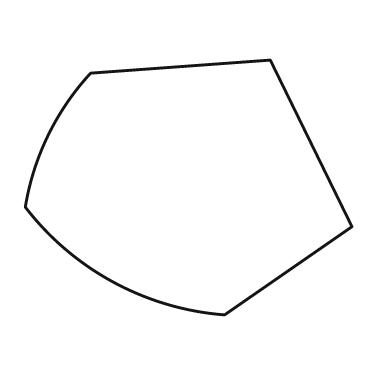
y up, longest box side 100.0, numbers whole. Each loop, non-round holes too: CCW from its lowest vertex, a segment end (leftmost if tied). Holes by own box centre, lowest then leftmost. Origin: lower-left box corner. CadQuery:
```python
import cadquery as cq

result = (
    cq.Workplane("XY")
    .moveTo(61.0, 0.0)
    .lineTo(100.0, 27.0)
    .lineTo(75.0, 78.0)
    .lineTo(20.0, 74.0)
    .threePointArc((7.0, 55.0), (0.0, 33.0))
    .threePointArc((27.0, 10.0), (61.0, 0.0))
    .close()
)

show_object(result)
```